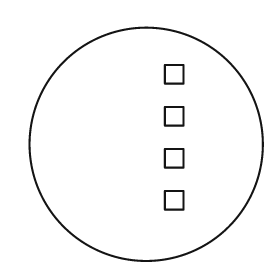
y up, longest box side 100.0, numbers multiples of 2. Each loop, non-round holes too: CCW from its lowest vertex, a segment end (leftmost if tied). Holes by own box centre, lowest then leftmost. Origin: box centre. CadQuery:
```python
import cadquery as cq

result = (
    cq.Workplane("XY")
    .moveTo(0.0, 0.0)
    .circle(50.0)
    .moveTo(8.0, -28.0)
    .lineTo(16.0, -28.0)
    .lineTo(16.0, -20.0)
    .lineTo(8.0, -20.0)
    .close()
    .moveTo(8.0, -10.0)
    .lineTo(16.0, -10.0)
    .lineTo(16.0, -2.0)
    .lineTo(8.0, -2.0)
    .close()
    .moveTo(8.0, 8.0)
    .lineTo(16.0, 8.0)
    .lineTo(16.0, 16.0)
    .lineTo(8.0, 16.0)
    .close()
    .moveTo(8.0, 26.0)
    .lineTo(16.0, 26.0)
    .lineTo(16.0, 34.0)
    .lineTo(8.0, 34.0)
    .close()
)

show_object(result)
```